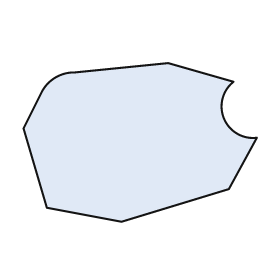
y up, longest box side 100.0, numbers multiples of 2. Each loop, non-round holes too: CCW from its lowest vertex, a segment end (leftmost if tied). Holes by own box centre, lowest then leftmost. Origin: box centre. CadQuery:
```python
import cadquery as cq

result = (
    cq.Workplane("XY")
    .moveTo(-8.0, -34.0)
    .lineTo(38.0, -20.0)
    .lineTo(50.0, 2.0)
    .threePointArc((36.0, 10.0), (40.0, 26.0))
    .lineTo(12.0, 34.0)
    .lineTo(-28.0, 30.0)
    .threePointArc((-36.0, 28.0), (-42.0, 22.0))
    .lineTo(-50.0, 6.0)
    .lineTo(-40.0, -28.0)
    .close()
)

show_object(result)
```